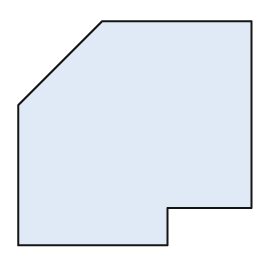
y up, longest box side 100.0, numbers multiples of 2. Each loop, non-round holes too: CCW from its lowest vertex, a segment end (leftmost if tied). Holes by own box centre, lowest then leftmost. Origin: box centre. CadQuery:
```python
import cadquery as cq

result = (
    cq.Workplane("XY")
    .moveTo(-50.0, -48.0)
    .lineTo(14.0, -48.0)
    .lineTo(14.0, -32.0)
    .lineTo(50.0, -32.0)
    .lineTo(50.0, 48.0)
    .lineTo(-14.0, 48.0)
    .lineTo(-50.0, 12.0)
    .close()
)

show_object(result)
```